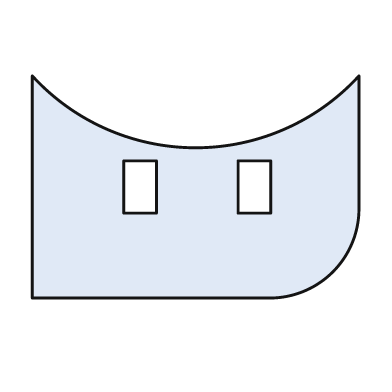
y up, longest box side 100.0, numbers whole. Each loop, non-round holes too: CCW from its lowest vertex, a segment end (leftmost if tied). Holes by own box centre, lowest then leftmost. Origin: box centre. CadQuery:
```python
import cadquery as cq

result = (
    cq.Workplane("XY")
    .moveTo(-50.0, -34.0)
    .lineTo(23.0, -34.0)
    .threePointArc((42.0, -26.0), (50.0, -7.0))
    .lineTo(50.0, 34.0)
    .threePointArc((0.0, 12.0), (-50.0, 34.0))
    .close()
    .moveTo(-22.0, -8.0)
    .lineTo(-12.0, -8.0)
    .lineTo(-12.0, 8.0)
    .lineTo(-22.0, 8.0)
    .close()
    .moveTo(13.0, -8.0)
    .lineTo(23.0, -8.0)
    .lineTo(23.0, 8.0)
    .lineTo(13.0, 8.0)
    .close()
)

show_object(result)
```